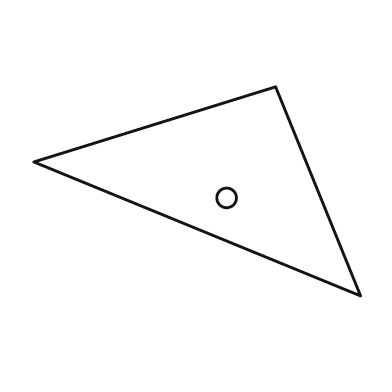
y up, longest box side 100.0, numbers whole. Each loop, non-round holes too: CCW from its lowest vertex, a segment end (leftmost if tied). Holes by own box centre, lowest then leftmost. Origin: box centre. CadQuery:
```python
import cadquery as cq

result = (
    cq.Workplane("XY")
    .moveTo(50.0, -32.0)
    .lineTo(24.0, 32.0)
    .lineTo(-50.0, 9.0)
    .close()
    .moveTo(9.0, -2.0)
    .circle(3.0)
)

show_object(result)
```